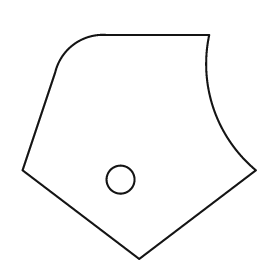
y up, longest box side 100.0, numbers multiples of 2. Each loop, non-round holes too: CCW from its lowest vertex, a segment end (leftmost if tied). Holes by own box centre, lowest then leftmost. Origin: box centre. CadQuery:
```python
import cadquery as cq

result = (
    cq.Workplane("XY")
    .moveTo(0.0, -48.0)
    .lineTo(50.0, -10.0)
    .threePointArc((32.0, 16.0), (30.0, 48.0))
    .lineTo(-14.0, 48.0)
    .threePointArc((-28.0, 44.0), (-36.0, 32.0))
    .lineTo(-50.0, -10.0)
    .close()
    .moveTo(-8.0, -14.0)
    .circle(6.0)
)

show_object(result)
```